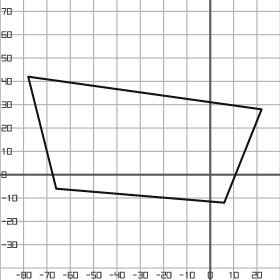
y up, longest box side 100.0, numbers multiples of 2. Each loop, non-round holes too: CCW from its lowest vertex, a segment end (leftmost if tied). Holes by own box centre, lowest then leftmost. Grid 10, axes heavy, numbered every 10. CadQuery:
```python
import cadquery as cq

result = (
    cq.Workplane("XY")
    .moveTo(6.0, -12.0)
    .lineTo(22.0, 28.0)
    .lineTo(-78.0, 42.0)
    .lineTo(-66.0, -6.0)
    .close()
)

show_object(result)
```